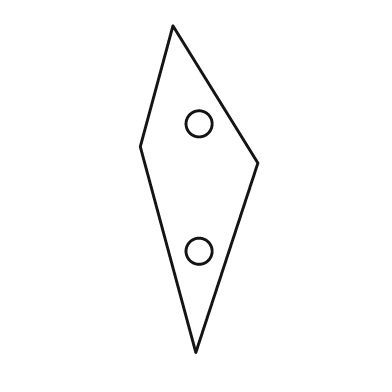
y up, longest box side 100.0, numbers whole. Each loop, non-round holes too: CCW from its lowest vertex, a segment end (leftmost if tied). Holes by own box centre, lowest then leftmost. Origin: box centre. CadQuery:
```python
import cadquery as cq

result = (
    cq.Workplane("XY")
    .moveTo(-1.0, -50.0)
    .lineTo(18.0, 8.0)
    .lineTo(-8.0, 50.0)
    .lineTo(-18.0, 13.0)
    .close()
    .moveTo(0.0, -19.0)
    .circle(4.0)
    .moveTo(0.0, 20.0)
    .circle(4.0)
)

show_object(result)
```